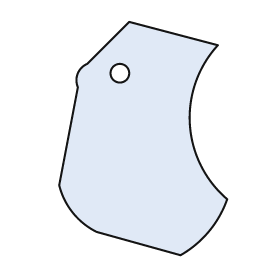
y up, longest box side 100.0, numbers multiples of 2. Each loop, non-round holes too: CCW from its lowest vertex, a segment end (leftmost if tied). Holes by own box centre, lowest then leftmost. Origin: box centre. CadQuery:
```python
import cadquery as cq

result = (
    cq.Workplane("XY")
    .moveTo(16.0, -50.0)
    .threePointArc((28.0, -40.0), (36.0, -26.0))
    .threePointArc((20.0, 6.0), (32.0, 40.0))
    .lineTo(-6.0, 50.0)
    .lineTo(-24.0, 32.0)
    .threePointArc((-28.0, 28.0), (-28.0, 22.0))
    .lineTo(-36.0, -20.0)
    .threePointArc((-30.0, -32.0), (-20.0, -40.0))
    .close()
    .moveTo(-10.0, 28.0)
    .circle(4.0)
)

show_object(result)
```